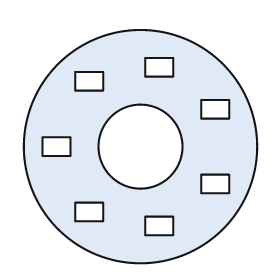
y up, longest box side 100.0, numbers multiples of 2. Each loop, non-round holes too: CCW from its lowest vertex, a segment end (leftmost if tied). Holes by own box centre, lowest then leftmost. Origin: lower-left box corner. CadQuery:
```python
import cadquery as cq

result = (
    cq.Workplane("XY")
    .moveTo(50.0, 50.0)
    .circle(50.0)
    .moveTo(52.0, 12.0)
    .lineTo(64.0, 12.0)
    .lineTo(64.0, 20.0)
    .lineTo(52.0, 20.0)
    .close()
    .moveTo(22.0, 18.0)
    .lineTo(34.0, 18.0)
    .lineTo(34.0, 26.0)
    .lineTo(22.0, 26.0)
    .close()
    .moveTo(76.0, 30.0)
    .lineTo(88.0, 30.0)
    .lineTo(88.0, 38.0)
    .lineTo(76.0, 38.0)
    .close()
    .moveTo(8.0, 46.0)
    .lineTo(20.0, 46.0)
    .lineTo(20.0, 54.0)
    .lineTo(8.0, 54.0)
    .close()
    .moveTo(50.0, 50.0)
    .circle(18.0)
    .moveTo(76.0, 62.0)
    .lineTo(88.0, 62.0)
    .lineTo(88.0, 70.0)
    .lineTo(76.0, 70.0)
    .close()
    .moveTo(22.0, 74.0)
    .lineTo(34.0, 74.0)
    .lineTo(34.0, 82.0)
    .lineTo(22.0, 82.0)
    .close()
    .moveTo(52.0, 80.0)
    .lineTo(64.0, 80.0)
    .lineTo(64.0, 88.0)
    .lineTo(52.0, 88.0)
    .close()
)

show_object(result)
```